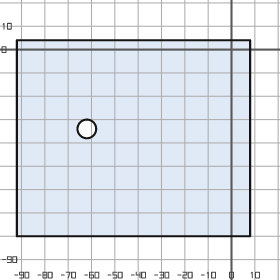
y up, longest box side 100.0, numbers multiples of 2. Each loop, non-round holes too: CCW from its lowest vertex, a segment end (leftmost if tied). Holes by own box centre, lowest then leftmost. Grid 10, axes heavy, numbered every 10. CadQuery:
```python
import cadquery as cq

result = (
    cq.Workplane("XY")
    .moveTo(-92.0, -80.0)
    .lineTo(8.0, -80.0)
    .lineTo(8.0, 4.0)
    .lineTo(-92.0, 4.0)
    .close()
    .moveTo(-62.0, -34.0)
    .circle(4.0)
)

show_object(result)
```